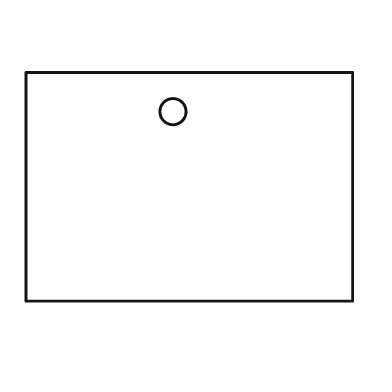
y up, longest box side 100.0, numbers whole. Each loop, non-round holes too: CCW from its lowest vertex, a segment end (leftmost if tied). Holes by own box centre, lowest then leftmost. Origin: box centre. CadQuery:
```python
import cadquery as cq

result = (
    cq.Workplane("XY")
    .moveTo(-50.0, -35.0)
    .lineTo(50.0, -35.0)
    .lineTo(50.0, 35.0)
    .lineTo(-50.0, 35.0)
    .close()
    .moveTo(-5.0, 23.0)
    .circle(4.0)
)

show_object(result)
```